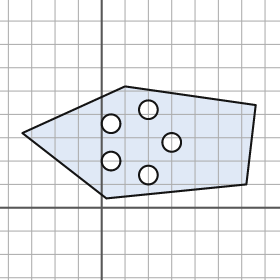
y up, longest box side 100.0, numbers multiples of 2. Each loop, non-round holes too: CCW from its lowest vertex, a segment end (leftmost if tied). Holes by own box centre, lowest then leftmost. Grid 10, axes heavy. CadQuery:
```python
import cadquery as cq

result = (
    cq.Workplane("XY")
    .moveTo(2.0, 4.0)
    .lineTo(62.0, 10.0)
    .lineTo(66.0, 44.0)
    .lineTo(10.0, 52.0)
    .lineTo(-34.0, 32.0)
    .close()
    .moveTo(20.0, 14.0)
    .circle(4.0)
    .moveTo(4.0, 20.0)
    .circle(4.0)
    .moveTo(30.0, 28.0)
    .circle(4.0)
    .moveTo(4.0, 36.0)
    .circle(4.0)
    .moveTo(20.0, 42.0)
    .circle(4.0)
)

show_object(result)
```